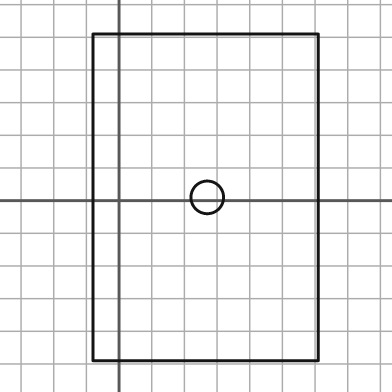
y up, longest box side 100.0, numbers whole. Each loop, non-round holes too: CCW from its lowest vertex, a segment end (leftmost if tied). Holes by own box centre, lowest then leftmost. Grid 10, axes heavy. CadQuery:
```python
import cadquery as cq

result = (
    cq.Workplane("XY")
    .moveTo(-8.0, -49.0)
    .lineTo(61.0, -49.0)
    .lineTo(61.0, 51.0)
    .lineTo(-8.0, 51.0)
    .close()
    .moveTo(27.0, 1.0)
    .circle(5.0)
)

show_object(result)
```